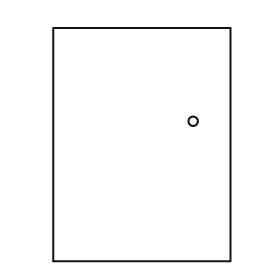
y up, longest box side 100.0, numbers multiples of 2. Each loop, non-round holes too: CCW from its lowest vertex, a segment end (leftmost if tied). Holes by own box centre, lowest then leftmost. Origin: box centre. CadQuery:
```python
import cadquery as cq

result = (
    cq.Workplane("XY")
    .moveTo(-38.0, -50.0)
    .lineTo(38.0, -50.0)
    .lineTo(38.0, 50.0)
    .lineTo(-38.0, 50.0)
    .close()
    .moveTo(22.0, 10.0)
    .circle(2.0)
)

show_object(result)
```